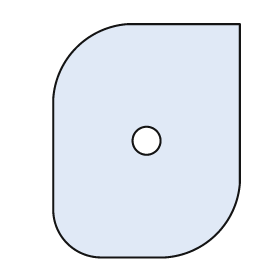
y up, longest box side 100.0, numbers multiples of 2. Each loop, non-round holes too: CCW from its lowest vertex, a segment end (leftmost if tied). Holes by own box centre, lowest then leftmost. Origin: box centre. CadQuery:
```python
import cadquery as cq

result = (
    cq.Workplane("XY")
    .moveTo(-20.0, -50.0)
    .lineTo(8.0, -50.0)
    .threePointArc((30.0, -40.0), (40.0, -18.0))
    .lineTo(40.0, 50.0)
    .lineTo(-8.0, 50.0)
    .threePointArc((-30.0, 40.0), (-40.0, 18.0))
    .lineTo(-40.0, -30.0)
    .threePointArc((-34.0, -44.0), (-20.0, -50.0))
    .close()
    .moveTo(0.0, 0.0)
    .circle(6.0)
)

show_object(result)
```